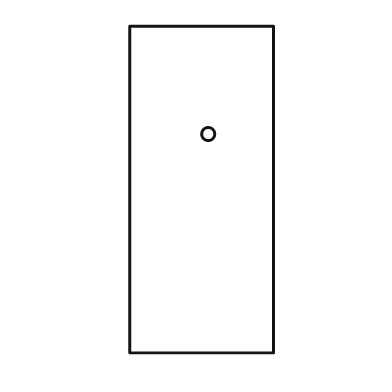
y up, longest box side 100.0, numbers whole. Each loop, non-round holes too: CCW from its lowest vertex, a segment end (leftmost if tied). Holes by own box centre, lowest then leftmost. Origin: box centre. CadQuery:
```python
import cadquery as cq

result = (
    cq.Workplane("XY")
    .moveTo(-22.0, -50.0)
    .lineTo(22.0, -50.0)
    .lineTo(22.0, 50.0)
    .lineTo(-22.0, 50.0)
    .close()
    .moveTo(2.0, 17.0)
    .circle(2.0)
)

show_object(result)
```